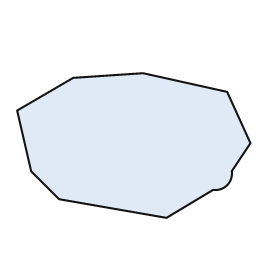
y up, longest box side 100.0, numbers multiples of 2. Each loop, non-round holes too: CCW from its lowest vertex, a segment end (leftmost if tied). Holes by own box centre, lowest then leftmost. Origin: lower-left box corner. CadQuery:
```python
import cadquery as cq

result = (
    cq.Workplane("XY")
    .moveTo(64.0, 0.0)
    .lineTo(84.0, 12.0)
    .threePointArc((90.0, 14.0), (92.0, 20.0))
    .lineTo(100.0, 32.0)
    .lineTo(90.0, 54.0)
    .lineTo(54.0, 62.0)
    .lineTo(24.0, 60.0)
    .lineTo(0.0, 46.0)
    .lineTo(6.0, 20.0)
    .lineTo(18.0, 8.0)
    .close()
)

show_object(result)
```